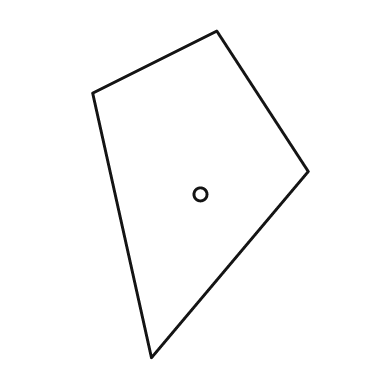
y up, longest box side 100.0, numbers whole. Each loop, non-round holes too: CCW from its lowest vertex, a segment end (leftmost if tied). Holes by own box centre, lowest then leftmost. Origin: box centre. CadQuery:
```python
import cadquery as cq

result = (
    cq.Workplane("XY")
    .moveTo(-15.0, -50.0)
    .lineTo(33.0, 7.0)
    .lineTo(5.0, 50.0)
    .lineTo(-33.0, 31.0)
    .close()
    .moveTo(0.0, 0.0)
    .circle(2.0)
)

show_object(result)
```